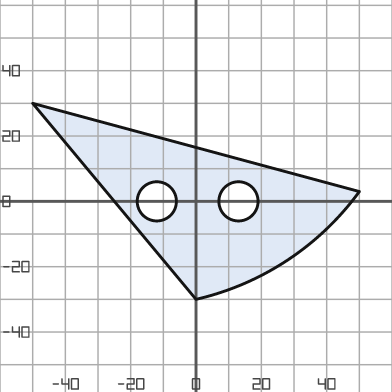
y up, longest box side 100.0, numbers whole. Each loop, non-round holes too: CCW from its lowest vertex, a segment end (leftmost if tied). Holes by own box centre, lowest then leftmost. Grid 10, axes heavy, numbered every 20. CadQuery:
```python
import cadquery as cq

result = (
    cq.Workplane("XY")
    .moveTo(0.0, -30.0)
    .threePointArc((28.0, -18.0), (50.0, 3.0))
    .lineTo(-50.0, 30.0)
    .close()
    .moveTo(-12.0, 0.0)
    .circle(6.0)
    .moveTo(13.0, 0.0)
    .circle(6.0)
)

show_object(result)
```